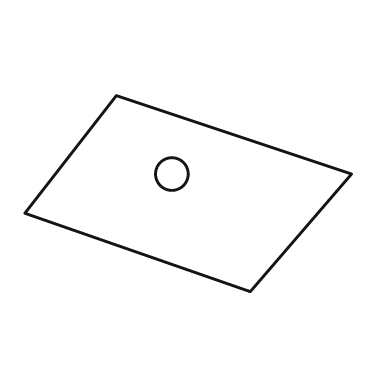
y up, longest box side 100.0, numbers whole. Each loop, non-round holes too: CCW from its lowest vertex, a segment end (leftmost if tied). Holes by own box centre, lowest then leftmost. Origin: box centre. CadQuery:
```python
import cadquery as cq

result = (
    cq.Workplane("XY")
    .moveTo(19.0, -30.0)
    .lineTo(50.0, 6.0)
    .lineTo(-22.0, 30.0)
    .lineTo(-50.0, -6.0)
    .close()
    .moveTo(-5.0, 6.0)
    .circle(5.0)
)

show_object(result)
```